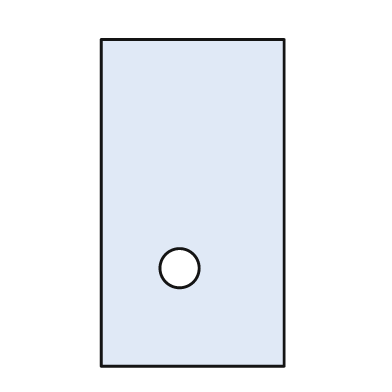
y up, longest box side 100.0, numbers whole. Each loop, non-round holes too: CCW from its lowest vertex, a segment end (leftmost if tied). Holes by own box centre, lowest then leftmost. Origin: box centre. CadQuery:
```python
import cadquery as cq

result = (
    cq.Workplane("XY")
    .moveTo(-28.0, -50.0)
    .lineTo(28.0, -50.0)
    .lineTo(28.0, 50.0)
    .lineTo(-28.0, 50.0)
    .close()
    .moveTo(-4.0, -20.0)
    .circle(6.0)
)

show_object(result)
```